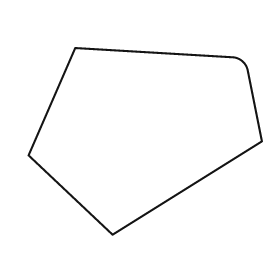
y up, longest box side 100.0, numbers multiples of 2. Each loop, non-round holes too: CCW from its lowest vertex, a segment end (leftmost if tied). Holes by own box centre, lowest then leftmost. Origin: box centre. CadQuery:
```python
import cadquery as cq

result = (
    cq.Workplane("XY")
    .moveTo(-14.0, -40.0)
    .lineTo(50.0, 0.0)
    .lineTo(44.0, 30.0)
    .threePointArc((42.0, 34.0), (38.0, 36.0))
    .lineTo(-30.0, 40.0)
    .lineTo(-50.0, -6.0)
    .close()
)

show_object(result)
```